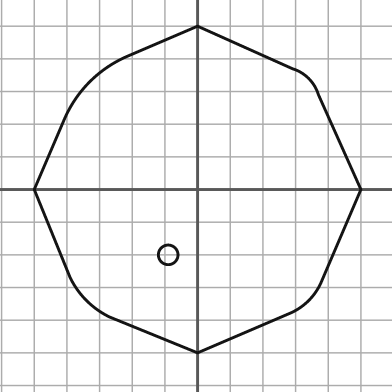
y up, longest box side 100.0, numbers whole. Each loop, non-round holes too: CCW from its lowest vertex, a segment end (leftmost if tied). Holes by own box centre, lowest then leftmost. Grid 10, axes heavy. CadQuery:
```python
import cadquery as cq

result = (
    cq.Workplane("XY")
    .moveTo(0.0, -50.0)
    .lineTo(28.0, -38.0)
    .threePointArc((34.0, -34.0), (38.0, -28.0))
    .lineTo(50.0, 0.0)
    .lineTo(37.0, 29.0)
    .threePointArc((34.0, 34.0), (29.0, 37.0))
    .lineTo(0.0, 50.0)
    .lineTo(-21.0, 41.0)
    .threePointArc((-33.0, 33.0), (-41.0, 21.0))
    .lineTo(-50.0, 0.0)
    .lineTo(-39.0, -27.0)
    .threePointArc((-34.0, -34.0), (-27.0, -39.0))
    .close()
    .moveTo(-9.0, -20.0)
    .circle(3.0)
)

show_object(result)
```